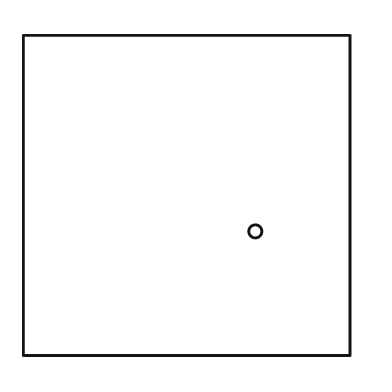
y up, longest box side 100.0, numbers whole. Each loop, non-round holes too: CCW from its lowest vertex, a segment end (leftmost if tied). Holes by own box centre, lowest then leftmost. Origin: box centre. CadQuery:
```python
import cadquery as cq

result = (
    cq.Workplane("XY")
    .moveTo(-50.0, -49.0)
    .lineTo(50.0, -49.0)
    .lineTo(50.0, 49.0)
    .lineTo(-50.0, 49.0)
    .close()
    .moveTo(21.0, -11.0)
    .circle(2.0)
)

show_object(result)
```